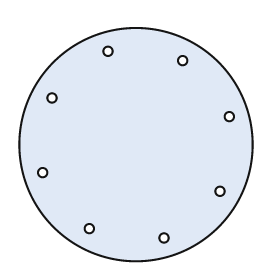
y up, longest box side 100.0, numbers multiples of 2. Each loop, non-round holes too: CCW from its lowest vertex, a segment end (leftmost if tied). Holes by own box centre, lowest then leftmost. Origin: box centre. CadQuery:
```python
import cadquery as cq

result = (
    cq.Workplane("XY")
    .moveTo(0.0, 0.0)
    .circle(50.0)
    .moveTo(12.0, -40.0)
    .circle(2.0)
    .moveTo(-20.0, -36.0)
    .circle(2.0)
    .moveTo(36.0, -20.0)
    .circle(2.0)
    .moveTo(-40.0, -12.0)
    .circle(2.0)
    .moveTo(40.0, 12.0)
    .circle(2.0)
    .moveTo(-36.0, 20.0)
    .circle(2.0)
    .moveTo(20.0, 36.0)
    .circle(2.0)
    .moveTo(-12.0, 40.0)
    .circle(2.0)
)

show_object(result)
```